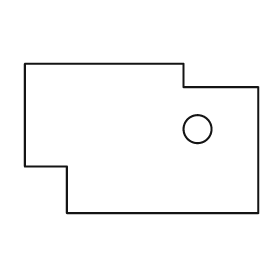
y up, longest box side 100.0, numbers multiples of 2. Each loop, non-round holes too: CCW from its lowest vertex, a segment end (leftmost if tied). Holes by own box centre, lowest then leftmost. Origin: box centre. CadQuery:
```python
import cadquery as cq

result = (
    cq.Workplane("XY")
    .moveTo(-32.0, -32.0)
    .lineTo(50.0, -32.0)
    .lineTo(50.0, 22.0)
    .lineTo(18.0, 22.0)
    .lineTo(18.0, 32.0)
    .lineTo(-50.0, 32.0)
    .lineTo(-50.0, -12.0)
    .lineTo(-32.0, -12.0)
    .close()
    .moveTo(24.0, 4.0)
    .circle(6.0)
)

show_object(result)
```